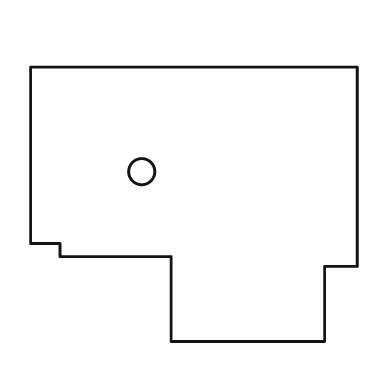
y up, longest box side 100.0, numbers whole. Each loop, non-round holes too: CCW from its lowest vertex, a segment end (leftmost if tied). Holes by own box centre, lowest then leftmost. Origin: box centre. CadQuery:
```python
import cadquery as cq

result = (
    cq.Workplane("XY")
    .moveTo(-7.0, -42.0)
    .lineTo(40.0, -42.0)
    .lineTo(40.0, -19.0)
    .lineTo(50.0, -19.0)
    .lineTo(50.0, 42.0)
    .lineTo(-50.0, 42.0)
    .lineTo(-50.0, -12.0)
    .lineTo(-41.0, -12.0)
    .lineTo(-41.0, -16.0)
    .lineTo(-7.0, -16.0)
    .close()
    .moveTo(-16.0, 10.0)
    .circle(4.0)
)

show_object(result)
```